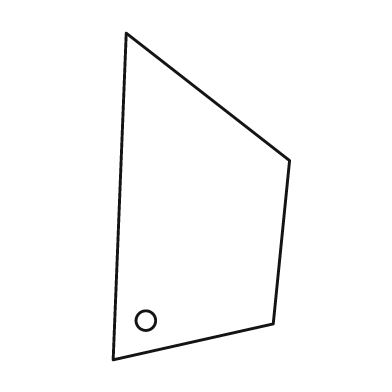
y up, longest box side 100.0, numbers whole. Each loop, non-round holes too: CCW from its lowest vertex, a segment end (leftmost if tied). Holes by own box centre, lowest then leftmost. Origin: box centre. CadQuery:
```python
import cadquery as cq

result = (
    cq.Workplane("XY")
    .moveTo(-27.0, -50.0)
    .lineTo(22.0, -39.0)
    .lineTo(27.0, 11.0)
    .lineTo(-23.0, 50.0)
    .close()
    .moveTo(-17.0, -38.0)
    .circle(3.0)
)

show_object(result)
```